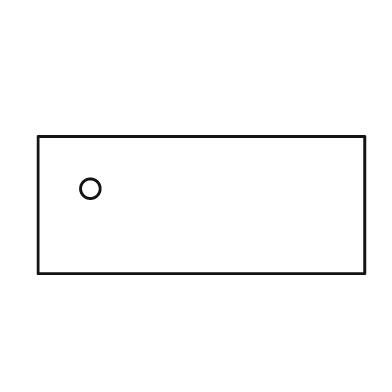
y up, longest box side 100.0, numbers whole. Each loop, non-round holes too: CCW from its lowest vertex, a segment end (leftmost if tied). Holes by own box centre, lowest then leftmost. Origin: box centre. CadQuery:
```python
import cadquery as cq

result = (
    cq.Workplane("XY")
    .moveTo(-50.0, -21.0)
    .lineTo(50.0, -21.0)
    .lineTo(50.0, 21.0)
    .lineTo(-50.0, 21.0)
    .close()
    .moveTo(-34.0, 5.0)
    .circle(3.0)
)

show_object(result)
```